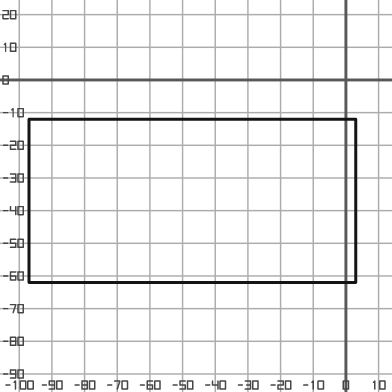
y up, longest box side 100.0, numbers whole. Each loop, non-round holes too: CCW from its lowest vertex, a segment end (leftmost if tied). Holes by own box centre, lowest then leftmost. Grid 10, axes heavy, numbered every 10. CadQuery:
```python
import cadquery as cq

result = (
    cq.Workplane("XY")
    .moveTo(-97.0, -62.0)
    .lineTo(3.0, -62.0)
    .lineTo(3.0, -12.0)
    .lineTo(-97.0, -12.0)
    .close()
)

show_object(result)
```